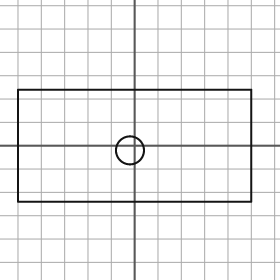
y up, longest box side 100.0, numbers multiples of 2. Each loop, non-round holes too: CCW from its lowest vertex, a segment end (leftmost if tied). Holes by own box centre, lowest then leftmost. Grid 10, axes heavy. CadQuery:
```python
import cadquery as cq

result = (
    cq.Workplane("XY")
    .moveTo(-50.0, -24.0)
    .lineTo(50.0, -24.0)
    .lineTo(50.0, 24.0)
    .lineTo(-50.0, 24.0)
    .close()
    .moveTo(-2.0, -2.0)
    .circle(6.0)
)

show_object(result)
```